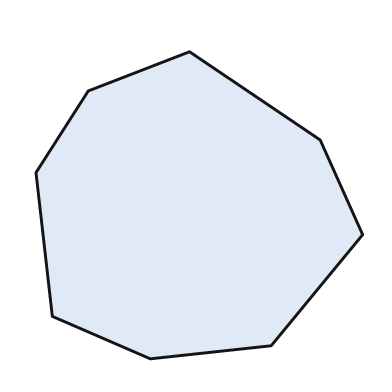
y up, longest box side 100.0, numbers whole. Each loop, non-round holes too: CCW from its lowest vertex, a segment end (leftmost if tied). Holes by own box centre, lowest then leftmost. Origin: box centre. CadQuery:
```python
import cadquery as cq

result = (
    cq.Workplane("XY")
    .moveTo(-15.0, -47.0)
    .lineTo(22.0, -43.0)
    .lineTo(50.0, -9.0)
    .lineTo(37.0, 20.0)
    .lineTo(-3.0, 47.0)
    .lineTo(-34.0, 35.0)
    .lineTo(-50.0, 10.0)
    .lineTo(-45.0, -34.0)
    .close()
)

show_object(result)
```